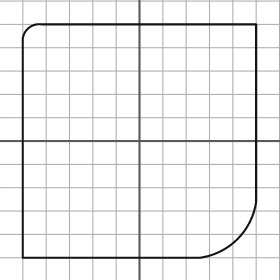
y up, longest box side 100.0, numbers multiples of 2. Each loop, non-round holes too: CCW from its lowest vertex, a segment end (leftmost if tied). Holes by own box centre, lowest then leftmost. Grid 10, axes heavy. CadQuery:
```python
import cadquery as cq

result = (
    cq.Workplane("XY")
    .moveTo(-50.0, -50.0)
    .lineTo(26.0, -50.0)
    .threePointArc((42.0, -42.0), (50.0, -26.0))
    .lineTo(50.0, 50.0)
    .lineTo(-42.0, 50.0)
    .threePointArc((-48.0, 48.0), (-50.0, 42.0))
    .close()
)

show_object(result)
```